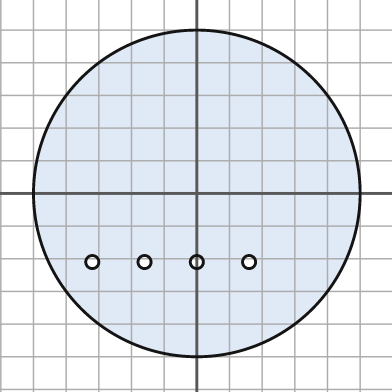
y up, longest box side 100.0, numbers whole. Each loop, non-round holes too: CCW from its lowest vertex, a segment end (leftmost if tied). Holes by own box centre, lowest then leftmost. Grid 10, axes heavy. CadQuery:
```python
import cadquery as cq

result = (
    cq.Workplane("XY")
    .moveTo(0.0, 0.0)
    .circle(50.0)
    .moveTo(-32.0, -21.0)
    .circle(2.0)
    .moveTo(-16.0, -21.0)
    .circle(2.0)
    .moveTo(0.0, -21.0)
    .circle(2.0)
    .moveTo(16.0, -21.0)
    .circle(2.0)
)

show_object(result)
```